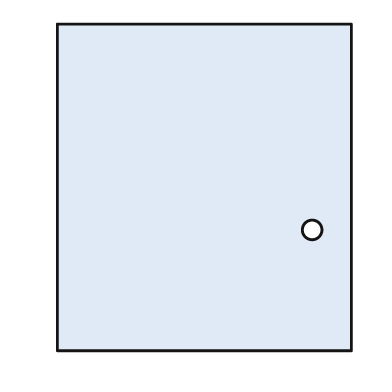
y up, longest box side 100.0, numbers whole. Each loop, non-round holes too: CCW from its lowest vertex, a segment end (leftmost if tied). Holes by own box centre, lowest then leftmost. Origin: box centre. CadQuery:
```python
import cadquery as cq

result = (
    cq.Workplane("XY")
    .moveTo(-45.0, -50.0)
    .lineTo(45.0, -50.0)
    .lineTo(45.0, 50.0)
    .lineTo(-45.0, 50.0)
    .close()
    .moveTo(33.0, -13.0)
    .circle(3.0)
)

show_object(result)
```